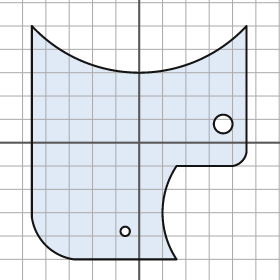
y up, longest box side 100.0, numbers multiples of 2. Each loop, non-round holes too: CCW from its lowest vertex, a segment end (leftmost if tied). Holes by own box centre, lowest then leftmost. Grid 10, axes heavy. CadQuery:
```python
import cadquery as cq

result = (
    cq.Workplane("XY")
    .moveTo(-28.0, -50.0)
    .lineTo(16.0, -50.0)
    .threePointArc((10.0, -30.0), (16.0, -10.0))
    .lineTo(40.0, -10.0)
    .threePointArc((44.0, -8.0), (46.0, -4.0))
    .lineTo(46.0, 50.0)
    .threePointArc((0.0, 30.0), (-46.0, 50.0))
    .lineTo(-46.0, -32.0)
    .threePointArc((-40.0, -44.0), (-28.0, -50.0))
    .close()
    .moveTo(-6.0, -38.0)
    .circle(2.0)
    .moveTo(36.0, 8.0)
    .circle(4.0)
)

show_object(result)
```